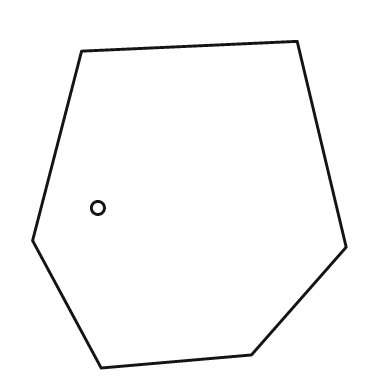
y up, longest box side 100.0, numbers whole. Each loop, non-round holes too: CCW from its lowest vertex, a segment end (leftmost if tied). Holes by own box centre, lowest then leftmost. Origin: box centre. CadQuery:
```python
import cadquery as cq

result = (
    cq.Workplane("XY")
    .moveTo(-27.0, -50.0)
    .lineTo(19.0, -46.0)
    .lineTo(48.0, -13.0)
    .lineTo(33.0, 50.0)
    .lineTo(-33.0, 47.0)
    .lineTo(-48.0, -11.0)
    .close()
    .moveTo(-28.0, -1.0)
    .circle(2.0)
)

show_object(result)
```